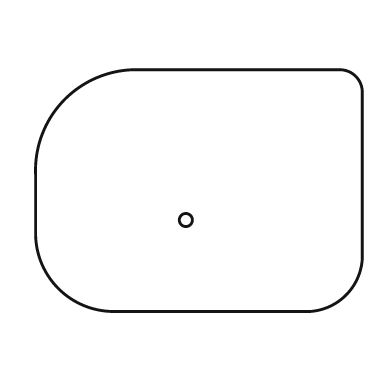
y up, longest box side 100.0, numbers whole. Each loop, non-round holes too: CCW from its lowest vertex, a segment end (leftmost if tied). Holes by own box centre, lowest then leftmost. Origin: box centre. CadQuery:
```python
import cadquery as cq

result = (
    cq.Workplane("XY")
    .moveTo(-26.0, -37.0)
    .lineTo(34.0, -37.0)
    .threePointArc((45.0, -32.0), (50.0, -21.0))
    .lineTo(50.0, 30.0)
    .threePointArc((48.0, 35.0), (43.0, 37.0))
    .lineTo(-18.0, 37.0)
    .threePointArc((-41.0, 28.0), (-50.0, 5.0))
    .lineTo(-50.0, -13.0)
    .threePointArc((-43.0, -30.0), (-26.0, -37.0))
    .close()
    .moveTo(-4.0, -9.0)
    .circle(2.0)
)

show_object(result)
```